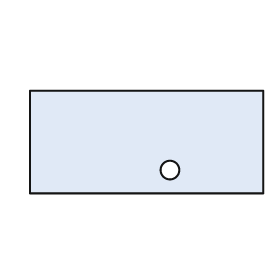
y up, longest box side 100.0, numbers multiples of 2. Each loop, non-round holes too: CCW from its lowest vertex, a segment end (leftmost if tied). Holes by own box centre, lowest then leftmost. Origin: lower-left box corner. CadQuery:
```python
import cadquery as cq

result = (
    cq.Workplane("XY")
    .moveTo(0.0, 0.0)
    .lineTo(100.0, 0.0)
    .lineTo(100.0, 44.0)
    .lineTo(0.0, 44.0)
    .close()
    .moveTo(60.0, 10.0)
    .circle(4.0)
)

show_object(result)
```